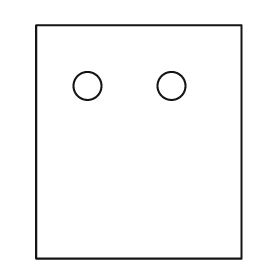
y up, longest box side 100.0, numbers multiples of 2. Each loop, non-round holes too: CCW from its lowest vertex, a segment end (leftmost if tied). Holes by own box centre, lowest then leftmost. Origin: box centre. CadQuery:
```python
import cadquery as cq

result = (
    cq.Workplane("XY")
    .moveTo(-44.0, -50.0)
    .lineTo(44.0, -50.0)
    .lineTo(44.0, 50.0)
    .lineTo(-44.0, 50.0)
    .close()
    .moveTo(-22.0, 24.0)
    .circle(6.0)
    .moveTo(14.0, 24.0)
    .circle(6.0)
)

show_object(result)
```